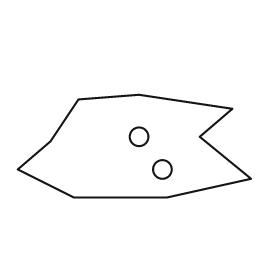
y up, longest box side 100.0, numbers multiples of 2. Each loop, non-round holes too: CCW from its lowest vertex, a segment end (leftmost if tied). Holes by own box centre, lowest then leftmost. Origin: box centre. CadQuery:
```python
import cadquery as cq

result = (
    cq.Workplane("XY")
    .moveTo(-26.0, -22.0)
    .lineTo(14.0, -22.0)
    .lineTo(50.0, -14.0)
    .lineTo(28.0, 4.0)
    .lineTo(42.0, 16.0)
    .lineTo(2.0, 22.0)
    .lineTo(-24.0, 20.0)
    .lineTo(-36.0, 2.0)
    .lineTo(-50.0, -10.0)
    .close()
    .moveTo(12.0, -10.0)
    .circle(4.0)
    .moveTo(2.0, 4.0)
    .circle(4.0)
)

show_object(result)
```